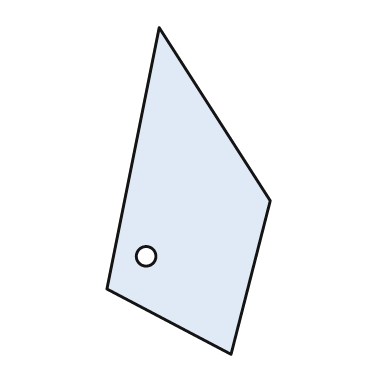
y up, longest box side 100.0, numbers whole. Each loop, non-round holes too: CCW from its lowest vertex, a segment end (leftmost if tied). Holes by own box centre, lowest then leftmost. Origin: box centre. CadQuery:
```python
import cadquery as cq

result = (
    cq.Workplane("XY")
    .moveTo(13.0, -50.0)
    .lineTo(25.0, -3.0)
    .lineTo(-9.0, 50.0)
    .lineTo(-25.0, -30.0)
    .close()
    .moveTo(-13.0, -20.0)
    .circle(3.0)
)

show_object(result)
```